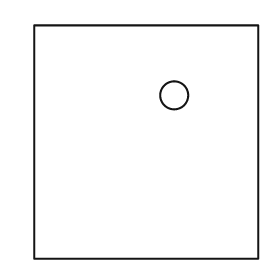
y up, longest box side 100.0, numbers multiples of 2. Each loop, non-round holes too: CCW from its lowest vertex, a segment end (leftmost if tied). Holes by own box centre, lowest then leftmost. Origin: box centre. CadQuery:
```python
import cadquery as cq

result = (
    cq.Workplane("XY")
    .moveTo(-48.0, -50.0)
    .lineTo(48.0, -50.0)
    .lineTo(48.0, 50.0)
    .lineTo(-48.0, 50.0)
    .close()
    .moveTo(12.0, 20.0)
    .circle(6.0)
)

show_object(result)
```